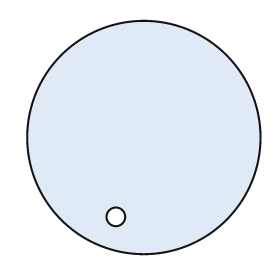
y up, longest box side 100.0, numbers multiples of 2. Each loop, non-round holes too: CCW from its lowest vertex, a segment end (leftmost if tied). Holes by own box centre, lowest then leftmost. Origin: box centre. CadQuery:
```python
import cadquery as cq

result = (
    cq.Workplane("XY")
    .moveTo(0.0, 0.0)
    .circle(50.0)
    .moveTo(-12.0, -34.0)
    .circle(4.0)
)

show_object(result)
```